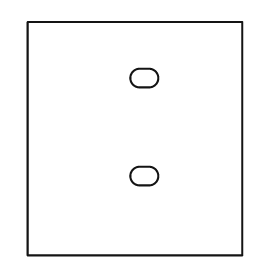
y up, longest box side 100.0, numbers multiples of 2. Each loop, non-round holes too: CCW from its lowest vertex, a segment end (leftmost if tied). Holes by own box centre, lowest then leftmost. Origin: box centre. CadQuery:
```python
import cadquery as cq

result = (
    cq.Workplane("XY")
    .moveTo(-46.0, -50.0)
    .lineTo(46.0, -50.0)
    .lineTo(46.0, 50.0)
    .lineTo(-46.0, 50.0)
    .close()
    .moveTo(2.0, -20.0)
    .lineTo(6.0, -20.0)
    .threePointArc((10.0, -16.0), (6.0, -12.0))
    .lineTo(2.0, -12.0)
    .threePointArc((-2.0, -16.0), (2.0, -20.0))
    .close()
    .moveTo(2.0, 22.0)
    .lineTo(6.0, 22.0)
    .threePointArc((10.0, 26.0), (6.0, 30.0))
    .lineTo(2.0, 30.0)
    .threePointArc((-2.0, 26.0), (2.0, 22.0))
    .close()
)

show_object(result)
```